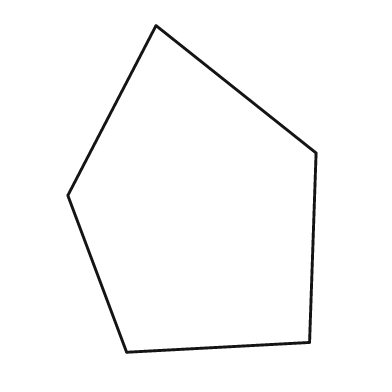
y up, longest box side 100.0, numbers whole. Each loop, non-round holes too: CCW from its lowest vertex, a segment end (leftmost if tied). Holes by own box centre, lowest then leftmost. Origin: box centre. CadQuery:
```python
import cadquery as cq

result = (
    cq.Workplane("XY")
    .moveTo(-20.0, -50.0)
    .lineTo(36.0, -47.0)
    .lineTo(38.0, 11.0)
    .lineTo(-11.0, 50.0)
    .lineTo(-38.0, -2.0)
    .close()
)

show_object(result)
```